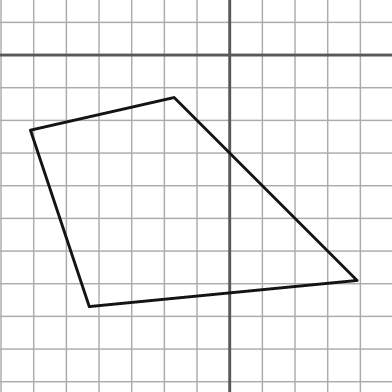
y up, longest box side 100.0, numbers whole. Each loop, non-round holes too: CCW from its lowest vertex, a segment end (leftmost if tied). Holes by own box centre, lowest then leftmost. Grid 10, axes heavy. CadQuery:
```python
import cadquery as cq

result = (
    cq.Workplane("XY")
    .moveTo(-43.0, -77.0)
    .lineTo(39.0, -69.0)
    .lineTo(-17.0, -13.0)
    .lineTo(-61.0, -23.0)
    .close()
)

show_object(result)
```